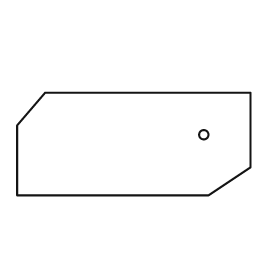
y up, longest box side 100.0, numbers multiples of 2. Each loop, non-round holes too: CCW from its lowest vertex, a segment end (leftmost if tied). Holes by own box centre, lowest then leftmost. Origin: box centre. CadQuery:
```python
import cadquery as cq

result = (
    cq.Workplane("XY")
    .moveTo(-50.0, -22.0)
    .lineTo(32.0, -22.0)
    .lineTo(50.0, -10.0)
    .lineTo(50.0, 22.0)
    .lineTo(-38.0, 22.0)
    .lineTo(-50.0, 8.0)
    .close()
    .moveTo(30.0, 4.0)
    .circle(2.0)
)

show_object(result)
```